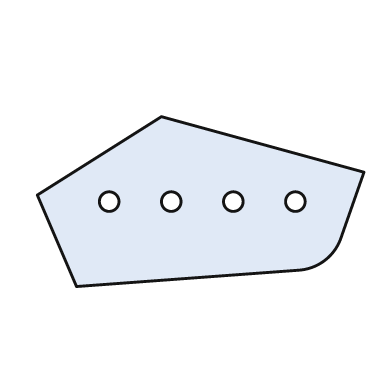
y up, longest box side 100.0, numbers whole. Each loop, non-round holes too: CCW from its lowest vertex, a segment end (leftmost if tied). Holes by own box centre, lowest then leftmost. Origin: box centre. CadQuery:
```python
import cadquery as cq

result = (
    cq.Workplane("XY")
    .moveTo(-38.0, -26.0)
    .lineTo(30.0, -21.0)
    .threePointArc((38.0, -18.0), (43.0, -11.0))
    .lineTo(50.0, 9.0)
    .lineTo(-12.0, 26.0)
    .lineTo(-50.0, 2.0)
    .close()
    .moveTo(-28.0, 0.0)
    .circle(3.0)
    .moveTo(-9.0, 0.0)
    .circle(3.0)
    .moveTo(10.0, 0.0)
    .circle(3.0)
    .moveTo(29.0, 0.0)
    .circle(3.0)
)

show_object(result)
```